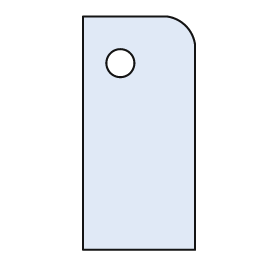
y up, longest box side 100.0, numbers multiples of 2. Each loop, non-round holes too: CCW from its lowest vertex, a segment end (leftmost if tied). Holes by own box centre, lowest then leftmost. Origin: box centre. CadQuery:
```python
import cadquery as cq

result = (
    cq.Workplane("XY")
    .moveTo(-24.0, -50.0)
    .lineTo(24.0, -50.0)
    .lineTo(24.0, 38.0)
    .threePointArc((20.0, 46.0), (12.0, 50.0))
    .lineTo(-24.0, 50.0)
    .close()
    .moveTo(-8.0, 30.0)
    .circle(6.0)
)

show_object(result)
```